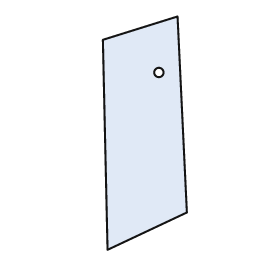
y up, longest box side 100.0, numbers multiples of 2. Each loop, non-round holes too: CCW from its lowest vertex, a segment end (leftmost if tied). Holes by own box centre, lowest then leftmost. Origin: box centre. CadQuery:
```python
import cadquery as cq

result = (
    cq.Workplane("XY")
    .moveTo(-16.0, -50.0)
    .lineTo(18.0, -34.0)
    .lineTo(14.0, 50.0)
    .lineTo(-18.0, 40.0)
    .close()
    .moveTo(6.0, 26.0)
    .circle(2.0)
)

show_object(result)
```